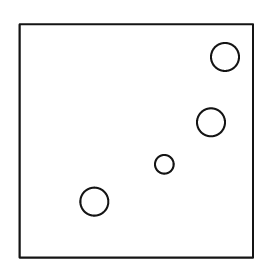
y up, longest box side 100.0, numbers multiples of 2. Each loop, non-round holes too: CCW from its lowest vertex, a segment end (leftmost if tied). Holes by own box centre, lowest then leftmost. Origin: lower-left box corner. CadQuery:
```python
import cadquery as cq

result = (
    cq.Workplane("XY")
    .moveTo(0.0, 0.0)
    .lineTo(100.0, 0.0)
    .lineTo(100.0, 100.0)
    .lineTo(0.0, 100.0)
    .close()
    .moveTo(32.0, 24.0)
    .circle(6.0)
    .moveTo(62.0, 40.0)
    .circle(4.0)
    .moveTo(82.0, 58.0)
    .circle(6.0)
    .moveTo(88.0, 86.0)
    .circle(6.0)
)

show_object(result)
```